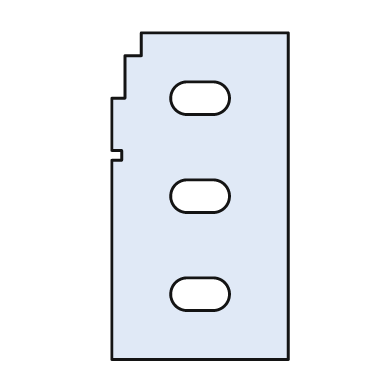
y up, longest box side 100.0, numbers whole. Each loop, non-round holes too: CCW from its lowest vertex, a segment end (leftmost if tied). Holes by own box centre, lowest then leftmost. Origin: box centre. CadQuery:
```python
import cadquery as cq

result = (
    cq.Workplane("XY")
    .moveTo(-27.0, -50.0)
    .lineTo(27.0, -50.0)
    .lineTo(27.0, 50.0)
    .lineTo(-18.0, 50.0)
    .lineTo(-18.0, 43.0)
    .lineTo(-23.0, 43.0)
    .lineTo(-23.0, 30.0)
    .lineTo(-27.0, 30.0)
    .lineTo(-27.0, 14.0)
    .lineTo(-24.0, 14.0)
    .lineTo(-24.0, 11.0)
    .lineTo(-27.0, 11.0)
    .close()
    .moveTo(-4.0, -35.0)
    .lineTo(4.0, -35.0)
    .threePointArc((9.0, -30.0), (4.0, -25.0))
    .lineTo(-4.0, -25.0)
    .threePointArc((-9.0, -30.0), (-4.0, -35.0))
    .close()
    .moveTo(-4.0, -5.0)
    .lineTo(4.0, -5.0)
    .threePointArc((9.0, 0.0), (4.0, 5.0))
    .lineTo(-4.0, 5.0)
    .threePointArc((-9.0, 0.0), (-4.0, -5.0))
    .close()
    .moveTo(-4.0, 25.0)
    .lineTo(4.0, 25.0)
    .threePointArc((9.0, 30.0), (4.0, 35.0))
    .lineTo(-4.0, 35.0)
    .threePointArc((-9.0, 30.0), (-4.0, 25.0))
    .close()
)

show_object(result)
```